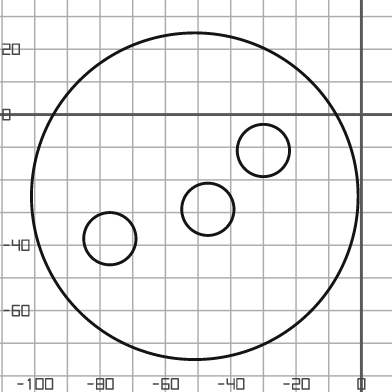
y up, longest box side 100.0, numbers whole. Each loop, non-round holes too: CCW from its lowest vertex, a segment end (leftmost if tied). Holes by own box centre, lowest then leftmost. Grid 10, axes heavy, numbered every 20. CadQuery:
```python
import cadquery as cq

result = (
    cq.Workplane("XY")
    .moveTo(-51.0, -25.0)
    .circle(50.0)
    .moveTo(-77.0, -38.0)
    .circle(8.0)
    .moveTo(-47.0, -29.0)
    .circle(8.0)
    .moveTo(-30.0, -11.0)
    .circle(8.0)
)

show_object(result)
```